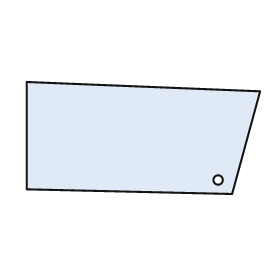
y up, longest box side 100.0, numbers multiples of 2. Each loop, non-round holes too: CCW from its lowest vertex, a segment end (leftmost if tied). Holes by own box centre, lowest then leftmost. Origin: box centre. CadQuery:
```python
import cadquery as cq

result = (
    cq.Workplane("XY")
    .moveTo(38.0, -24.0)
    .lineTo(50.0, 20.0)
    .lineTo(-50.0, 24.0)
    .lineTo(-50.0, -22.0)
    .close()
    .moveTo(32.0, -18.0)
    .circle(2.0)
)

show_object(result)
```